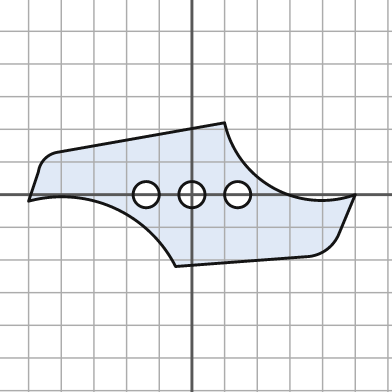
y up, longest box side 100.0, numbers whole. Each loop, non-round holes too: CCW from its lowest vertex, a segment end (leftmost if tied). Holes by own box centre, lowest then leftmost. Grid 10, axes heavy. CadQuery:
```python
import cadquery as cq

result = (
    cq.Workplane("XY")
    .moveTo(-5.0, -22.0)
    .lineTo(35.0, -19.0)
    .threePointArc((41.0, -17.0), (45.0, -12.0))
    .lineTo(50.0, 0.0)
    .threePointArc((25.0, 2.0), (10.0, 22.0))
    .lineTo(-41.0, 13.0)
    .threePointArc((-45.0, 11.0), (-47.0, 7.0))
    .lineTo(-50.0, -2.0)
    .threePointArc((-24.0, -4.0), (-5.0, -22.0))
    .close()
    .moveTo(-14.0, 0.0)
    .circle(4.0)
    .moveTo(0.0, 0.0)
    .circle(4.0)
    .moveTo(14.0, 0.0)
    .circle(4.0)
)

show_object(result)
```